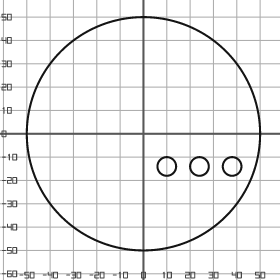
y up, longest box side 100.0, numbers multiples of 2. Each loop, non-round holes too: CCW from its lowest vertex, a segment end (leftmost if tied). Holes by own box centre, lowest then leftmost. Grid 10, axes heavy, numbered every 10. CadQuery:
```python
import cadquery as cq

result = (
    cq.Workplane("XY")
    .moveTo(0.0, 0.0)
    .circle(50.0)
    .moveTo(10.0, -14.0)
    .circle(4.0)
    .moveTo(24.0, -14.0)
    .circle(4.0)
    .moveTo(38.0, -14.0)
    .circle(4.0)
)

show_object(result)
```